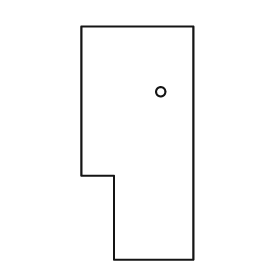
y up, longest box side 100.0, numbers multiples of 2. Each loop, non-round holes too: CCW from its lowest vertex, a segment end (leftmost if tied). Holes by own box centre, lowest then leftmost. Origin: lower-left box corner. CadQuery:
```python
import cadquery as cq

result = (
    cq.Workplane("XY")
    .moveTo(14.0, 0.0)
    .lineTo(48.0, 0.0)
    .lineTo(48.0, 100.0)
    .lineTo(0.0, 100.0)
    .lineTo(0.0, 36.0)
    .lineTo(14.0, 36.0)
    .close()
    .moveTo(34.0, 72.0)
    .circle(2.0)
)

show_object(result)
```